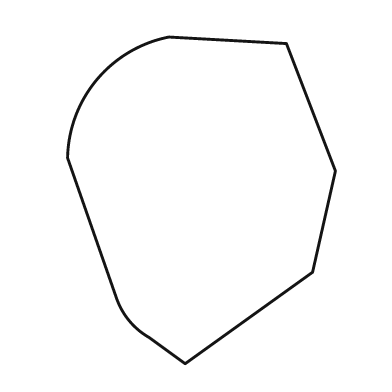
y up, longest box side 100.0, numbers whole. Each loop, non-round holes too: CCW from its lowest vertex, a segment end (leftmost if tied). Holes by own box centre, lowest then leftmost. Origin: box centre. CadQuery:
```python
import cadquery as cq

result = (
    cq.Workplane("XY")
    .moveTo(-5.0, -50.0)
    .lineTo(34.0, -22.0)
    .lineTo(41.0, 9.0)
    .lineTo(26.0, 48.0)
    .lineTo(-10.0, 50.0)
    .threePointArc((-32.0, 37.0), (-41.0, 13.0))
    .lineTo(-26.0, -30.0)
    .threePointArc((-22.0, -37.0), (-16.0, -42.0))
    .close()
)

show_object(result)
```